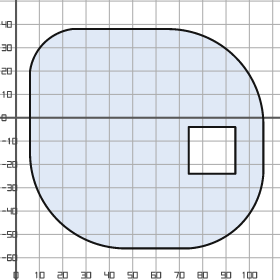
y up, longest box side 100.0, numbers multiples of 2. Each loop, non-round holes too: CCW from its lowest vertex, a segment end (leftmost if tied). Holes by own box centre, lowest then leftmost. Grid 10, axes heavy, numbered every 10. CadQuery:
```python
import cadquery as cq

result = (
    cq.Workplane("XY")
    .moveTo(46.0, -56.0)
    .lineTo(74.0, -56.0)
    .threePointArc((96.0, -46.0), (106.0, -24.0))
    .lineTo(106.0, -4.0)
    .threePointArc((94.0, 26.0), (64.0, 38.0))
    .lineTo(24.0, 38.0)
    .threePointArc((12.0, 32.0), (6.0, 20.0))
    .lineTo(6.0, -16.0)
    .threePointArc((18.0, -44.0), (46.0, -56.0))
    .close()
    .moveTo(74.0, -24.0)
    .lineTo(94.0, -24.0)
    .lineTo(94.0, -4.0)
    .lineTo(74.0, -4.0)
    .close()
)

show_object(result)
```